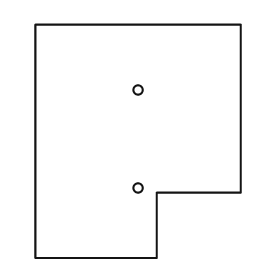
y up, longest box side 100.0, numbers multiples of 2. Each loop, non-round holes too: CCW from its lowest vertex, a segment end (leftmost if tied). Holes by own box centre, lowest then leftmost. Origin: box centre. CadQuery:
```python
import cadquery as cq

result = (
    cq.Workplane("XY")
    .moveTo(-44.0, -50.0)
    .lineTo(8.0, -50.0)
    .lineTo(8.0, -22.0)
    .lineTo(44.0, -22.0)
    .lineTo(44.0, 50.0)
    .lineTo(-44.0, 50.0)
    .close()
    .moveTo(0.0, -20.0)
    .circle(2.0)
    .moveTo(0.0, 22.0)
    .circle(2.0)
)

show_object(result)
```